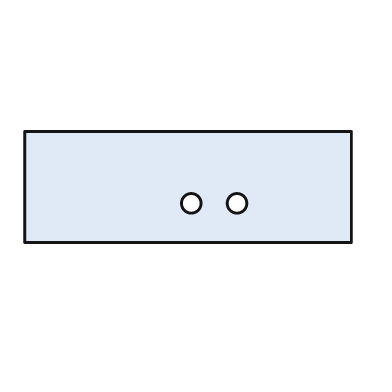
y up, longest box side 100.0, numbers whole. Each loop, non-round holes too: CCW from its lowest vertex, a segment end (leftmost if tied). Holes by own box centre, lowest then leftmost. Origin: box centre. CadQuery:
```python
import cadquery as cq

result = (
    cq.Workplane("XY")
    .moveTo(-50.0, -17.0)
    .lineTo(50.0, -17.0)
    .lineTo(50.0, 17.0)
    .lineTo(-50.0, 17.0)
    .close()
    .moveTo(1.0, -5.0)
    .circle(3.0)
    .moveTo(15.0, -5.0)
    .circle(3.0)
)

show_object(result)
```